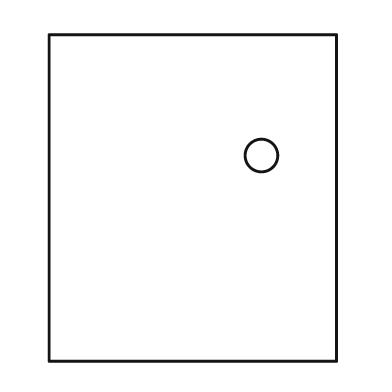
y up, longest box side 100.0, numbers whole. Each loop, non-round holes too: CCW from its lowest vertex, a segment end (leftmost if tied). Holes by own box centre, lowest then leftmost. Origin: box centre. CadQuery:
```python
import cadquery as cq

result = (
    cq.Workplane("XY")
    .moveTo(-44.0, -50.0)
    .lineTo(44.0, -50.0)
    .lineTo(44.0, 50.0)
    .lineTo(-44.0, 50.0)
    .close()
    .moveTo(21.0, 13.0)
    .circle(5.0)
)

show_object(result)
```